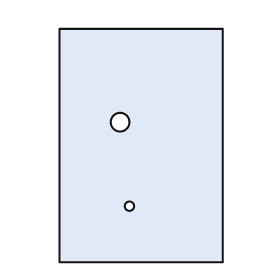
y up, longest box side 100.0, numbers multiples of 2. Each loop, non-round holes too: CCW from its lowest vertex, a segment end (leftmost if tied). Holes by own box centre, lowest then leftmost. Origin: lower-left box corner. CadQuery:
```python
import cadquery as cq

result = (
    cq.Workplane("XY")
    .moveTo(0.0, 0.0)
    .lineTo(70.0, 0.0)
    .lineTo(70.0, 100.0)
    .lineTo(0.0, 100.0)
    .close()
    .moveTo(30.0, 24.0)
    .circle(2.0)
    .moveTo(26.0, 60.0)
    .circle(4.0)
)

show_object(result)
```